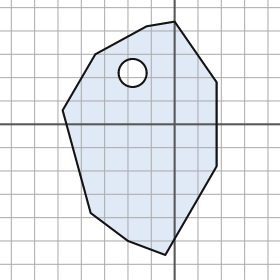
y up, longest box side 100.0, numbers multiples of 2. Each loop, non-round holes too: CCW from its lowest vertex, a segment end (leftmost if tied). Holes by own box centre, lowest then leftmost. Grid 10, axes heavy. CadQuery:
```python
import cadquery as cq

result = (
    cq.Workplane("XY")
    .moveTo(-4.0, -56.0)
    .lineTo(18.0, -18.0)
    .lineTo(18.0, 18.0)
    .lineTo(0.0, 44.0)
    .lineTo(-12.0, 42.0)
    .lineTo(-34.0, 30.0)
    .lineTo(-48.0, 6.0)
    .lineTo(-36.0, -38.0)
    .lineTo(-20.0, -50.0)
    .close()
    .moveTo(-18.0, 22.0)
    .circle(6.0)
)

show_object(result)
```